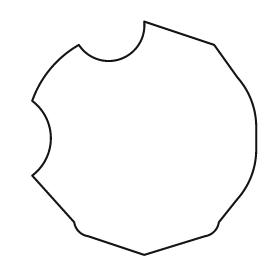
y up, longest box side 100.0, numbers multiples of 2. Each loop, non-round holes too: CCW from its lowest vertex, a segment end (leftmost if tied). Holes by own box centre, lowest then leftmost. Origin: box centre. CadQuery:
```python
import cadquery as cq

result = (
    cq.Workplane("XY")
    .moveTo(0.0, -50.0)
    .lineTo(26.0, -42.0)
    .threePointArc((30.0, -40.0), (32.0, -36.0))
    .lineTo(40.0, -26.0)
    .threePointArc((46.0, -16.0), (48.0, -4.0))
    .lineTo(48.0, 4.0)
    .threePointArc((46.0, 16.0), (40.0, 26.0))
    .lineTo(30.0, 40.0)
    .lineTo(0.0, 50.0)
    .threePointArc((-10.0, 34.0), (-28.0, 40.0))
    .threePointArc((-40.0, 30.0), (-48.0, 16.0))
    .threePointArc((-40.0, 0.0), (-48.0, -16.0))
    .lineTo(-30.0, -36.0)
    .threePointArc((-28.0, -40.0), (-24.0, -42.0))
    .close()
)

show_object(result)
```